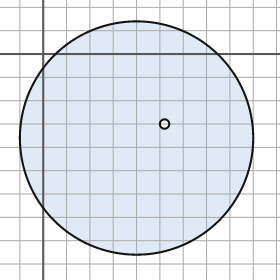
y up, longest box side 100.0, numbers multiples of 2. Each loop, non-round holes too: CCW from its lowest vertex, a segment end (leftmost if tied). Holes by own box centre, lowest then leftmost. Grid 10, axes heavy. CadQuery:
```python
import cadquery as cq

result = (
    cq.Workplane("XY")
    .moveTo(40.0, -36.0)
    .circle(50.0)
    .moveTo(52.0, -30.0)
    .circle(2.0)
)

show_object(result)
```